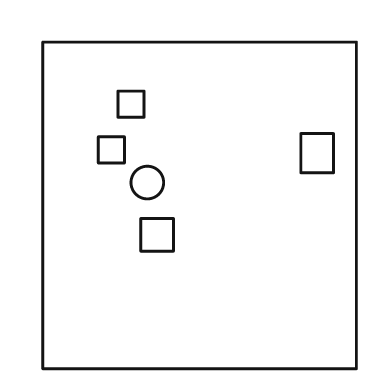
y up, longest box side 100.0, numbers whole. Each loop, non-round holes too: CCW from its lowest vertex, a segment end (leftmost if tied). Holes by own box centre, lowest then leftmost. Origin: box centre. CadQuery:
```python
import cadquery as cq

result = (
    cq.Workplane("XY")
    .moveTo(-48.0, -50.0)
    .lineTo(48.0, -50.0)
    .lineTo(48.0, 50.0)
    .lineTo(-48.0, 50.0)
    .close()
    .moveTo(-18.0, -14.0)
    .lineTo(-8.0, -14.0)
    .lineTo(-8.0, -4.0)
    .lineTo(-18.0, -4.0)
    .close()
    .moveTo(-16.0, 7.0)
    .circle(5.0)
    .moveTo(31.0, 10.0)
    .lineTo(41.0, 10.0)
    .lineTo(41.0, 22.0)
    .lineTo(31.0, 22.0)
    .close()
    .moveTo(-31.0, 13.0)
    .lineTo(-23.0, 13.0)
    .lineTo(-23.0, 21.0)
    .lineTo(-31.0, 21.0)
    .close()
    .moveTo(-25.0, 27.0)
    .lineTo(-17.0, 27.0)
    .lineTo(-17.0, 35.0)
    .lineTo(-25.0, 35.0)
    .close()
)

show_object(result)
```